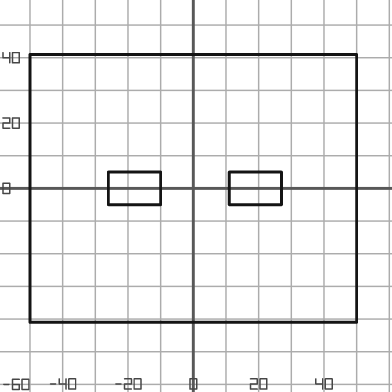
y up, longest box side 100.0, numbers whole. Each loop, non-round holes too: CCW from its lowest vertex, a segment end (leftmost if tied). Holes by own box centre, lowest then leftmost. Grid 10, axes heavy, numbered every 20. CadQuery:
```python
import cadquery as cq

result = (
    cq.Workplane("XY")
    .moveTo(-50.0, -41.0)
    .lineTo(50.0, -41.0)
    .lineTo(50.0, 41.0)
    .lineTo(-50.0, 41.0)
    .close()
    .moveTo(-26.0, -5.0)
    .lineTo(-10.0, -5.0)
    .lineTo(-10.0, 5.0)
    .lineTo(-26.0, 5.0)
    .close()
    .moveTo(11.0, -5.0)
    .lineTo(27.0, -5.0)
    .lineTo(27.0, 5.0)
    .lineTo(11.0, 5.0)
    .close()
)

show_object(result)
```